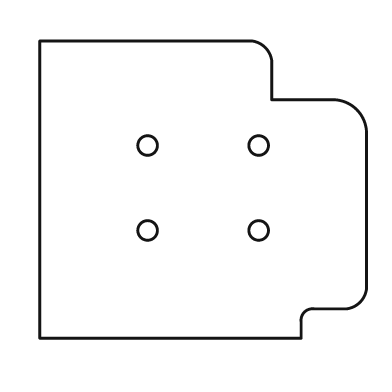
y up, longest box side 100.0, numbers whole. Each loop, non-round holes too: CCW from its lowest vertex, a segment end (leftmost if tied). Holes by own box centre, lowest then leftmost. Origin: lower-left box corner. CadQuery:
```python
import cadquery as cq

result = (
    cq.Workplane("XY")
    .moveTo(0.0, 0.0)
    .lineTo(80.0, 0.0)
    .lineTo(80.0, 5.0)
    .threePointArc((81.0, 8.0), (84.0, 9.0))
    .lineTo(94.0, 9.0)
    .threePointArc((98.0, 11.0), (100.0, 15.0))
    .lineTo(100.0, 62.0)
    .threePointArc((97.0, 70.0), (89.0, 73.0))
    .lineTo(71.0, 73.0)
    .lineTo(71.0, 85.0)
    .threePointArc((69.0, 89.0), (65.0, 91.0))
    .lineTo(0.0, 91.0)
    .close()
    .moveTo(33.0, 33.0)
    .circle(3.0)
    .moveTo(67.0, 33.0)
    .circle(3.0)
    .moveTo(33.0, 59.0)
    .circle(3.0)
    .moveTo(67.0, 59.0)
    .circle(3.0)
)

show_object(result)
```